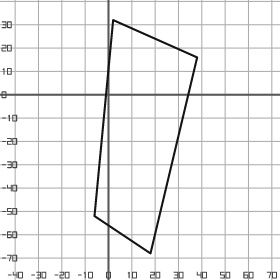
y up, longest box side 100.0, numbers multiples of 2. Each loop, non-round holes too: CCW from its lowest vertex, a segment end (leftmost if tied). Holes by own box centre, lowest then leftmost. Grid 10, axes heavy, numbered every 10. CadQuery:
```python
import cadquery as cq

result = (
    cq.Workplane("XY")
    .moveTo(18.0, -68.0)
    .lineTo(38.0, 16.0)
    .lineTo(2.0, 32.0)
    .lineTo(-6.0, -52.0)
    .close()
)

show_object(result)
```